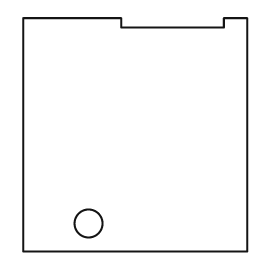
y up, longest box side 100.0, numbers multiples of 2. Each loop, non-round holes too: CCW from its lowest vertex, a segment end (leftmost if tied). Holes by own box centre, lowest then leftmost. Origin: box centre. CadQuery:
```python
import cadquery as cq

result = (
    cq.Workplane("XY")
    .moveTo(-48.0, -50.0)
    .lineTo(48.0, -50.0)
    .lineTo(48.0, 50.0)
    .lineTo(38.0, 50.0)
    .lineTo(38.0, 46.0)
    .lineTo(-6.0, 46.0)
    .lineTo(-6.0, 50.0)
    .lineTo(-48.0, 50.0)
    .close()
    .moveTo(-20.0, -38.0)
    .circle(6.0)
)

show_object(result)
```